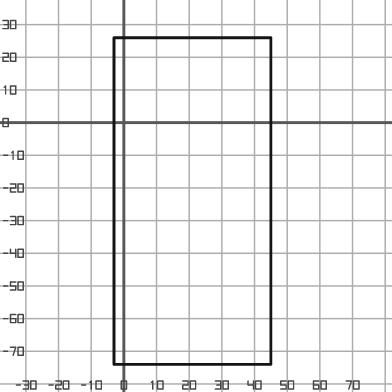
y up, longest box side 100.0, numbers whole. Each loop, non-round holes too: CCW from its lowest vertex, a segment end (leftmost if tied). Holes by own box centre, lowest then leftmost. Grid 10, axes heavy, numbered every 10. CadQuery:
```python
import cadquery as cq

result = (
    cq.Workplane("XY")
    .moveTo(-3.0, -74.0)
    .lineTo(45.0, -74.0)
    .lineTo(45.0, 26.0)
    .lineTo(-3.0, 26.0)
    .close()
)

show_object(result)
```